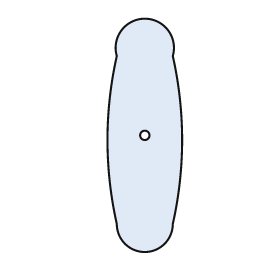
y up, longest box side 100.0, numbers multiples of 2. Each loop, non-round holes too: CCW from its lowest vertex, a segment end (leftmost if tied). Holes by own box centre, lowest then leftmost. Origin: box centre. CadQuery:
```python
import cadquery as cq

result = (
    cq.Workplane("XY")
    .moveTo(-12.0, -38.0)
    .threePointArc((0.0, -50.0), (12.0, -38.0))
    .threePointArc((16.0, -2.0), (12.0, 34.0))
    .threePointArc((0.0, 50.0), (-12.0, 34.0))
    .threePointArc((-16.0, -2.0), (-12.0, -38.0))
    .close()
    .moveTo(0.0, 0.0)
    .circle(2.0)
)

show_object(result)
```